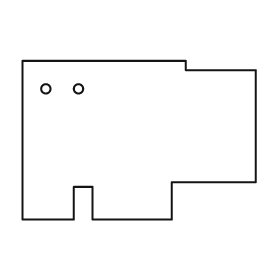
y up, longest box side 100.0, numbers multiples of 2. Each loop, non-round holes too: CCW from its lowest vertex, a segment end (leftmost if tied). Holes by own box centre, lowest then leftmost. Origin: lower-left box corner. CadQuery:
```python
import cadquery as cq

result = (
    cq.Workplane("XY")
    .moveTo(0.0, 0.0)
    .lineTo(22.0, 0.0)
    .lineTo(22.0, 14.0)
    .lineTo(30.0, 14.0)
    .lineTo(30.0, 0.0)
    .lineTo(64.0, 0.0)
    .lineTo(64.0, 16.0)
    .lineTo(100.0, 16.0)
    .lineTo(100.0, 64.0)
    .lineTo(70.0, 64.0)
    .lineTo(70.0, 68.0)
    .lineTo(0.0, 68.0)
    .close()
    .moveTo(10.0, 56.0)
    .circle(2.0)
    .moveTo(24.0, 56.0)
    .circle(2.0)
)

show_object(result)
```